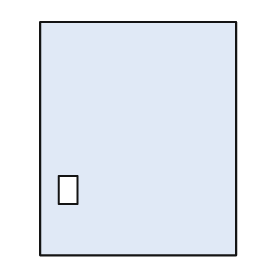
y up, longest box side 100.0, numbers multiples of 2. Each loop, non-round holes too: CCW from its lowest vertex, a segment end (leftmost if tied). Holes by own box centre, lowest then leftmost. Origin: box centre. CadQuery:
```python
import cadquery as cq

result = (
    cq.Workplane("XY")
    .moveTo(-42.0, -50.0)
    .lineTo(42.0, -50.0)
    .lineTo(42.0, 50.0)
    .lineTo(-42.0, 50.0)
    .close()
    .moveTo(-34.0, -28.0)
    .lineTo(-26.0, -28.0)
    .lineTo(-26.0, -16.0)
    .lineTo(-34.0, -16.0)
    .close()
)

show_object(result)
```